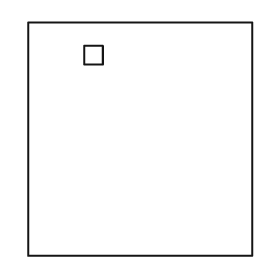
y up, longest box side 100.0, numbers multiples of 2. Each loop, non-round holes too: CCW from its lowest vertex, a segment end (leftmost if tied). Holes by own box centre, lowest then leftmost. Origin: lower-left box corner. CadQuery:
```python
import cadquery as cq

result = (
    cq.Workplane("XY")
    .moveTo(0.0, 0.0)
    .lineTo(96.0, 0.0)
    .lineTo(96.0, 100.0)
    .lineTo(0.0, 100.0)
    .close()
    .moveTo(24.0, 82.0)
    .lineTo(32.0, 82.0)
    .lineTo(32.0, 90.0)
    .lineTo(24.0, 90.0)
    .close()
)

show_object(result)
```